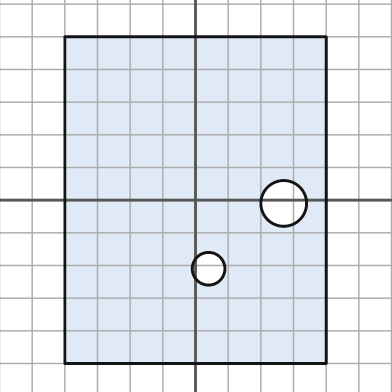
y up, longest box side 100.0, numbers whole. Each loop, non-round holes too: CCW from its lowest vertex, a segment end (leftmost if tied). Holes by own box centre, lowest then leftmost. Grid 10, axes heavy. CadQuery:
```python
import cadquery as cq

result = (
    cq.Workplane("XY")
    .moveTo(-40.0, -50.0)
    .lineTo(40.0, -50.0)
    .lineTo(40.0, 50.0)
    .lineTo(-40.0, 50.0)
    .close()
    .moveTo(4.0, -21.0)
    .circle(5.0)
    .moveTo(27.0, -1.0)
    .circle(7.0)
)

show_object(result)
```